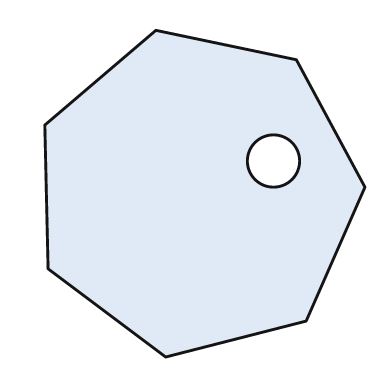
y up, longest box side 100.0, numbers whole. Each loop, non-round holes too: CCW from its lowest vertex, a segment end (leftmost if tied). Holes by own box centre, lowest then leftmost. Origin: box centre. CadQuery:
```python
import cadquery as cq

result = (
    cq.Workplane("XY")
    .moveTo(-12.0, -50.0)
    .lineTo(31.0, -39.0)
    .lineTo(49.0, 2.0)
    .lineTo(28.0, 41.0)
    .lineTo(-15.0, 50.0)
    .lineTo(-49.0, 21.0)
    .lineTo(-48.0, -23.0)
    .close()
    .moveTo(21.0, 10.0)
    .circle(8.0)
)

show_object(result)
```